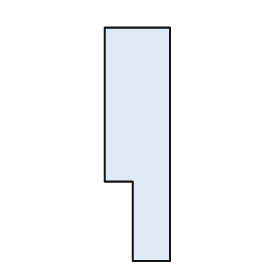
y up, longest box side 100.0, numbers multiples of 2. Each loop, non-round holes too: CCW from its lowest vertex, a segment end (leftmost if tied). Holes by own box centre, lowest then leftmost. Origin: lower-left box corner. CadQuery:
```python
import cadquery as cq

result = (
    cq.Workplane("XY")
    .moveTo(12.0, 0.0)
    .lineTo(28.0, 0.0)
    .lineTo(28.0, 100.0)
    .lineTo(0.0, 100.0)
    .lineTo(0.0, 34.0)
    .lineTo(12.0, 34.0)
    .close()
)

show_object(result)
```